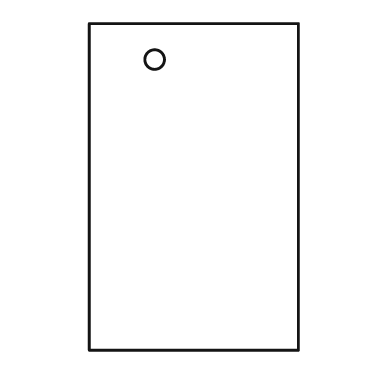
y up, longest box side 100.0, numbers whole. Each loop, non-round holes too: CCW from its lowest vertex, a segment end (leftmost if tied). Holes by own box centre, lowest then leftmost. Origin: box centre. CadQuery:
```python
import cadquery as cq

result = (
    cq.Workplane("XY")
    .moveTo(-32.0, -50.0)
    .lineTo(32.0, -50.0)
    .lineTo(32.0, 50.0)
    .lineTo(-32.0, 50.0)
    .close()
    .moveTo(-12.0, 39.0)
    .circle(3.0)
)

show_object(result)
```